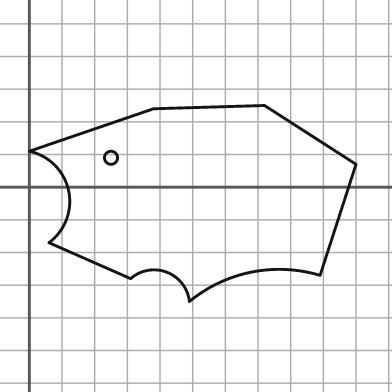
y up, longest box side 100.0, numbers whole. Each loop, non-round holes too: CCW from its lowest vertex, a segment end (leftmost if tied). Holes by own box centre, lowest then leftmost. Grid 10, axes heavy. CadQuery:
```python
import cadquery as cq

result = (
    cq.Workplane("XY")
    .moveTo(49.0, -35.0)
    .threePointArc((68.0, -26.0), (89.0, -27.0))
    .lineTo(100.0, 7.0)
    .lineTo(72.0, 25.0)
    .lineTo(38.0, 24.0)
    .lineTo(0.0, 11.0)
    .threePointArc((12.0, -1.0), (6.0, -17.0))
    .lineTo(31.0, -28.0)
    .threePointArc((42.0, -26.0), (49.0, -35.0))
    .close()
    .moveTo(25.0, 9.0)
    .circle(2.0)
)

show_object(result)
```